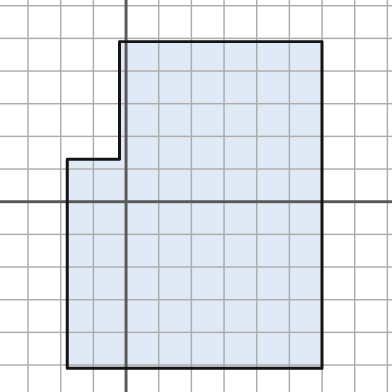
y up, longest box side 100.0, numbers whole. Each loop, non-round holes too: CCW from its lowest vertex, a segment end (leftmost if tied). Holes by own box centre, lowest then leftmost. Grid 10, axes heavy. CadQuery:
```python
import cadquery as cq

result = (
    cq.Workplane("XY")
    .moveTo(-18.0, -51.0)
    .lineTo(60.0, -51.0)
    .lineTo(60.0, 49.0)
    .lineTo(-2.0, 49.0)
    .lineTo(-2.0, 13.0)
    .lineTo(-18.0, 13.0)
    .close()
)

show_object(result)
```